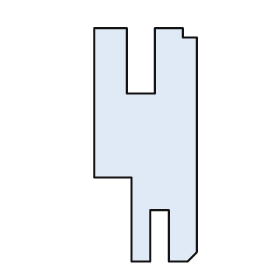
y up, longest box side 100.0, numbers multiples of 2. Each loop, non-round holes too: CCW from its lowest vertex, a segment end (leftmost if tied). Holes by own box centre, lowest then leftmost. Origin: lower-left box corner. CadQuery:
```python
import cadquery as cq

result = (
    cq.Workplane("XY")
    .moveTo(16.0, 0.0)
    .lineTo(24.0, 0.0)
    .lineTo(24.0, 22.0)
    .lineTo(32.0, 22.0)
    .lineTo(32.0, 0.0)
    .lineTo(40.0, 0.0)
    .lineTo(44.0, 4.0)
    .lineTo(44.0, 96.0)
    .lineTo(38.0, 96.0)
    .lineTo(38.0, 100.0)
    .lineTo(26.0, 100.0)
    .lineTo(26.0, 72.0)
    .lineTo(14.0, 72.0)
    .lineTo(14.0, 100.0)
    .lineTo(0.0, 100.0)
    .lineTo(0.0, 36.0)
    .lineTo(16.0, 36.0)
    .close()
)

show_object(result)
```